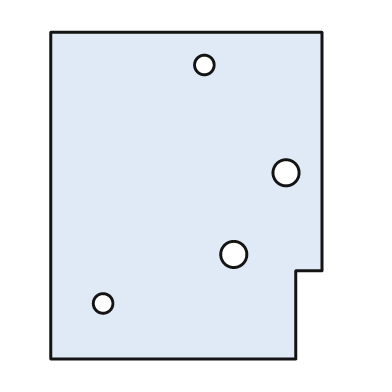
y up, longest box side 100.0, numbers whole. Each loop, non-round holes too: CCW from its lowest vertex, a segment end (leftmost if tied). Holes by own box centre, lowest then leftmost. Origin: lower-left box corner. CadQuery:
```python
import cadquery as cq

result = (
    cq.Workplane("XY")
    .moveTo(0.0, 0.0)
    .lineTo(75.0, 0.0)
    .lineTo(75.0, 27.0)
    .lineTo(83.0, 27.0)
    .lineTo(83.0, 100.0)
    .lineTo(0.0, 100.0)
    .close()
    .moveTo(16.0, 17.0)
    .circle(3.0)
    .moveTo(56.0, 32.0)
    .circle(4.0)
    .moveTo(72.0, 57.0)
    .circle(4.0)
    .moveTo(47.0, 90.0)
    .circle(3.0)
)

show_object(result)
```